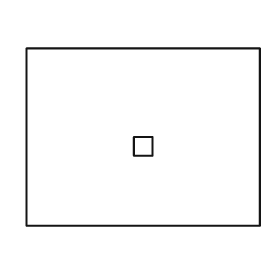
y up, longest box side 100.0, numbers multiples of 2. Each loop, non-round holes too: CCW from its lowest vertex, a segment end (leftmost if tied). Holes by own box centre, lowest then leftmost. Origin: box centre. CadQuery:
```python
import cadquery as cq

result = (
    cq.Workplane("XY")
    .moveTo(-50.0, -38.0)
    .lineTo(50.0, -38.0)
    .lineTo(50.0, 38.0)
    .lineTo(-50.0, 38.0)
    .close()
    .moveTo(-4.0, -8.0)
    .lineTo(4.0, -8.0)
    .lineTo(4.0, 0.0)
    .lineTo(-4.0, 0.0)
    .close()
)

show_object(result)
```